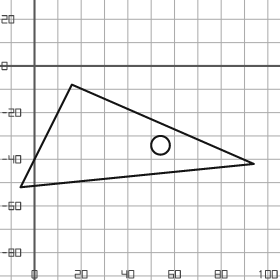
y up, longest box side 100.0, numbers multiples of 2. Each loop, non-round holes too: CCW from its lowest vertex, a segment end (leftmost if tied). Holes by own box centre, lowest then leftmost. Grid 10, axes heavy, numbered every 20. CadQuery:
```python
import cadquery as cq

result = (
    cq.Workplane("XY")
    .moveTo(-6.0, -52.0)
    .lineTo(94.0, -42.0)
    .lineTo(16.0, -8.0)
    .close()
    .moveTo(54.0, -34.0)
    .circle(4.0)
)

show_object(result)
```